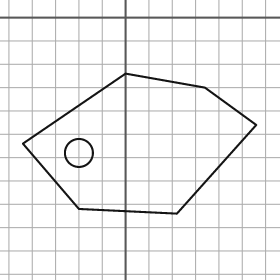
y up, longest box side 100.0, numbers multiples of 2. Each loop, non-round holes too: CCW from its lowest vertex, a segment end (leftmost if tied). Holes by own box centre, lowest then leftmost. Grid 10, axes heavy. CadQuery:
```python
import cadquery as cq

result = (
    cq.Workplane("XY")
    .moveTo(22.0, -84.0)
    .lineTo(56.0, -46.0)
    .lineTo(34.0, -30.0)
    .lineTo(0.0, -24.0)
    .lineTo(-44.0, -54.0)
    .lineTo(-20.0, -82.0)
    .close()
    .moveTo(-20.0, -58.0)
    .circle(6.0)
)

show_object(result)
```